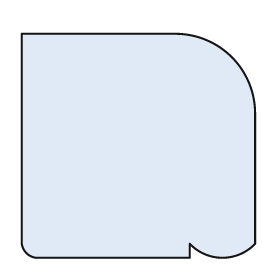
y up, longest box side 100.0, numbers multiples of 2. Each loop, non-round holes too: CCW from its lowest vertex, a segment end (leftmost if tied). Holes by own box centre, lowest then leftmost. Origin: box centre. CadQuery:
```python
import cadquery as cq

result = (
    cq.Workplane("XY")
    .moveTo(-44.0, -48.0)
    .lineTo(22.0, -48.0)
    .lineTo(22.0, -42.0)
    .threePointArc((36.0, -48.0), (50.0, -42.0))
    .lineTo(50.0, 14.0)
    .threePointArc((40.0, 38.0), (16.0, 48.0))
    .lineTo(-50.0, 48.0)
    .lineTo(-50.0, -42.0)
    .threePointArc((-48.0, -46.0), (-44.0, -48.0))
    .close()
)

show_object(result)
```